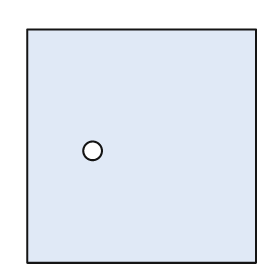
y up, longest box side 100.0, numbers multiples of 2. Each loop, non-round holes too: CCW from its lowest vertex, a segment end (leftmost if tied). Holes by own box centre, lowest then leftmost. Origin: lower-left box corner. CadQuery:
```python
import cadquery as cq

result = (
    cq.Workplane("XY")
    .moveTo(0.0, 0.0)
    .lineTo(98.0, 0.0)
    .lineTo(98.0, 100.0)
    .lineTo(0.0, 100.0)
    .close()
    .moveTo(28.0, 48.0)
    .circle(4.0)
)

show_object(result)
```